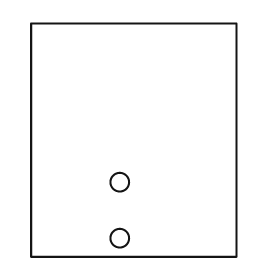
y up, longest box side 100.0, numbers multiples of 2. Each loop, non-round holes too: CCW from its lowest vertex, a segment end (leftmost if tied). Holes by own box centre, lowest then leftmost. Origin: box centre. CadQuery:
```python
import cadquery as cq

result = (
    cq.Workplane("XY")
    .moveTo(-44.0, -50.0)
    .lineTo(44.0, -50.0)
    .lineTo(44.0, 50.0)
    .lineTo(-44.0, 50.0)
    .close()
    .moveTo(-6.0, -42.0)
    .circle(4.0)
    .moveTo(-6.0, -18.0)
    .circle(4.0)
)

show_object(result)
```